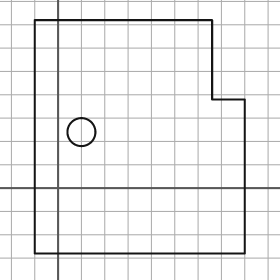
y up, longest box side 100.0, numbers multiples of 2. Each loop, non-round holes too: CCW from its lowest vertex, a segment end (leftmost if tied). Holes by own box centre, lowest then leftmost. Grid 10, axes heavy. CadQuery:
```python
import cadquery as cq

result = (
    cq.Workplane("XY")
    .moveTo(-10.0, -28.0)
    .lineTo(80.0, -28.0)
    .lineTo(80.0, 38.0)
    .lineTo(66.0, 38.0)
    .lineTo(66.0, 72.0)
    .lineTo(-10.0, 72.0)
    .close()
    .moveTo(10.0, 24.0)
    .circle(6.0)
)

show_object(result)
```